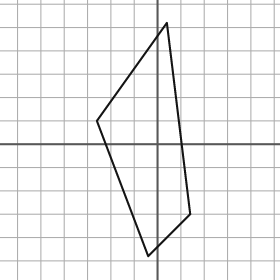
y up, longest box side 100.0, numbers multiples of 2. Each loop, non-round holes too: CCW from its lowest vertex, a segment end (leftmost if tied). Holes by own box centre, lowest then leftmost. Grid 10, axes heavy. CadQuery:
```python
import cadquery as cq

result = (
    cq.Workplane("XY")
    .moveTo(-4.0, -48.0)
    .lineTo(14.0, -30.0)
    .lineTo(4.0, 52.0)
    .lineTo(-26.0, 10.0)
    .close()
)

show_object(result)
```